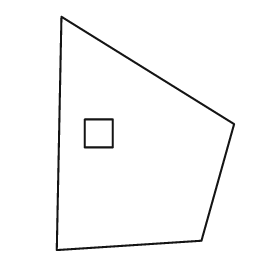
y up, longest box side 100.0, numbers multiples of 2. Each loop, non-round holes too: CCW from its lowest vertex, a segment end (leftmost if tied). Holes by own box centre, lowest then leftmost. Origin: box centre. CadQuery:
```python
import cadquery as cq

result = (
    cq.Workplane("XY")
    .moveTo(-38.0, -50.0)
    .lineTo(24.0, -46.0)
    .lineTo(38.0, 4.0)
    .lineTo(-36.0, 50.0)
    .close()
    .moveTo(-26.0, -6.0)
    .lineTo(-14.0, -6.0)
    .lineTo(-14.0, 6.0)
    .lineTo(-26.0, 6.0)
    .close()
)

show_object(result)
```